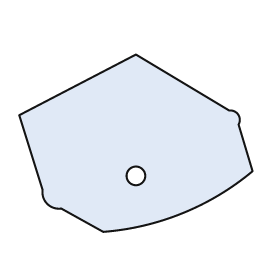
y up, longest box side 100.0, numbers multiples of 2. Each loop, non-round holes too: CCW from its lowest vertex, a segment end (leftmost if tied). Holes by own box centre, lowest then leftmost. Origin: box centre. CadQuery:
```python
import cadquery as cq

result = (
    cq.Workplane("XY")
    .moveTo(-14.0, -38.0)
    .threePointArc((20.0, -30.0), (50.0, -12.0))
    .lineTo(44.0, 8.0)
    .threePointArc((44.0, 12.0), (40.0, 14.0))
    .lineTo(0.0, 38.0)
    .lineTo(-50.0, 12.0)
    .lineTo(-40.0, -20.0)
    .threePointArc((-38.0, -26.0), (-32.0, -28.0))
    .close()
    .moveTo(0.0, -14.0)
    .circle(4.0)
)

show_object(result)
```